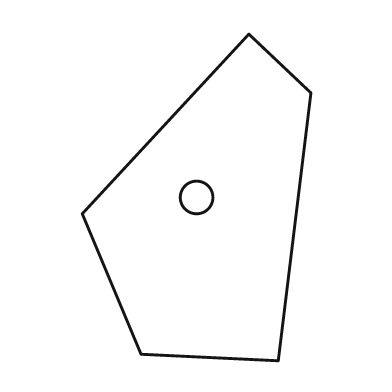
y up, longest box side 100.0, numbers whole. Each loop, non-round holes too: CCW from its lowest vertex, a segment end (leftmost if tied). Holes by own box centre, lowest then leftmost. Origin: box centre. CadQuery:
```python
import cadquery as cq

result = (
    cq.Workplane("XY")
    .moveTo(25.0, -50.0)
    .lineTo(35.0, 32.0)
    .lineTo(16.0, 50.0)
    .lineTo(-35.0, -5.0)
    .lineTo(-17.0, -48.0)
    .close()
    .moveTo(0.0, 0.0)
    .circle(5.0)
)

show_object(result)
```